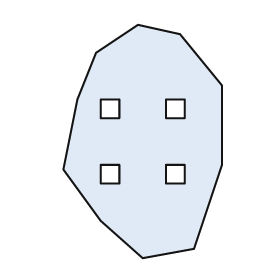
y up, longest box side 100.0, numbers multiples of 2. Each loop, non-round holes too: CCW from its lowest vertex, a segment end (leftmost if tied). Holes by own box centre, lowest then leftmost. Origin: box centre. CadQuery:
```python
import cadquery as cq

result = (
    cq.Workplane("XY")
    .moveTo(0.0, -50.0)
    .lineTo(22.0, -46.0)
    .lineTo(34.0, -10.0)
    .lineTo(34.0, 24.0)
    .lineTo(16.0, 46.0)
    .lineTo(-2.0, 50.0)
    .lineTo(-20.0, 38.0)
    .lineTo(-28.0, 18.0)
    .lineTo(-34.0, -12.0)
    .lineTo(-18.0, -34.0)
    .close()
    .moveTo(-18.0, -18.0)
    .lineTo(-10.0, -18.0)
    .lineTo(-10.0, -10.0)
    .lineTo(-18.0, -10.0)
    .close()
    .moveTo(10.0, -18.0)
    .lineTo(18.0, -18.0)
    .lineTo(18.0, -10.0)
    .lineTo(10.0, -10.0)
    .close()
    .moveTo(-18.0, 10.0)
    .lineTo(-10.0, 10.0)
    .lineTo(-10.0, 18.0)
    .lineTo(-18.0, 18.0)
    .close()
    .moveTo(10.0, 10.0)
    .lineTo(18.0, 10.0)
    .lineTo(18.0, 18.0)
    .lineTo(10.0, 18.0)
    .close()
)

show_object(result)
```